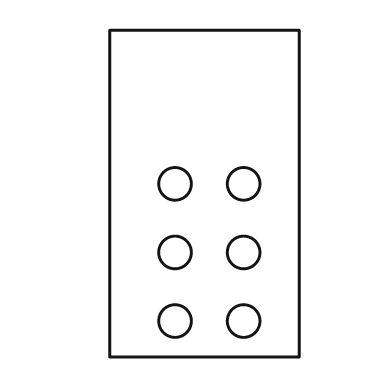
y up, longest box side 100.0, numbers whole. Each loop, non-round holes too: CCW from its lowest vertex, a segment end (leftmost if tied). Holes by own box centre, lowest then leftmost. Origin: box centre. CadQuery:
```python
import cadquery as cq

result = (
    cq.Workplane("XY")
    .moveTo(-29.0, -50.0)
    .lineTo(29.0, -50.0)
    .lineTo(29.0, 50.0)
    .lineTo(-29.0, 50.0)
    .close()
    .moveTo(-9.0, -39.0)
    .circle(5.0)
    .moveTo(12.0, -39.0)
    .circle(5.0)
    .moveTo(-9.0, -18.0)
    .circle(5.0)
    .moveTo(12.0, -18.0)
    .circle(5.0)
    .moveTo(-9.0, 3.0)
    .circle(5.0)
    .moveTo(12.0, 3.0)
    .circle(5.0)
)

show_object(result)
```